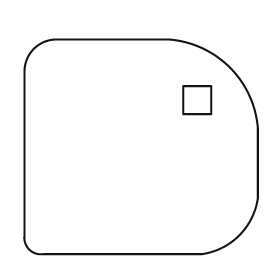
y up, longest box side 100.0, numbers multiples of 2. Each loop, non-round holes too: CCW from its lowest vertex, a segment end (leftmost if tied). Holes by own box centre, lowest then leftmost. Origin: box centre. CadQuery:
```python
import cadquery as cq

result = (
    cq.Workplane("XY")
    .moveTo(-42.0, -46.0)
    .lineTo(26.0, -46.0)
    .threePointArc((42.0, -38.0), (50.0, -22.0))
    .lineTo(50.0, 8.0)
    .threePointArc((38.0, 34.0), (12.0, 46.0))
    .lineTo(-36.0, 46.0)
    .threePointArc((-46.0, 42.0), (-50.0, 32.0))
    .lineTo(-50.0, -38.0)
    .threePointArc((-48.0, -44.0), (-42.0, -46.0))
    .close()
    .moveTo(18.0, 14.0)
    .lineTo(30.0, 14.0)
    .lineTo(30.0, 26.0)
    .lineTo(18.0, 26.0)
    .close()
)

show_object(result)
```